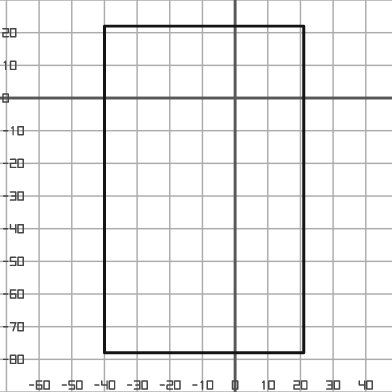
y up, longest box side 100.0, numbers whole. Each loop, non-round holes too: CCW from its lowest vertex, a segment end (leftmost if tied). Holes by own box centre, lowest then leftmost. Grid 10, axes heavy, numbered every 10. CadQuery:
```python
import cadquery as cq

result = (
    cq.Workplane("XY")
    .moveTo(-40.0, -78.0)
    .lineTo(21.0, -78.0)
    .lineTo(21.0, 22.0)
    .lineTo(-40.0, 22.0)
    .close()
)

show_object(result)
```